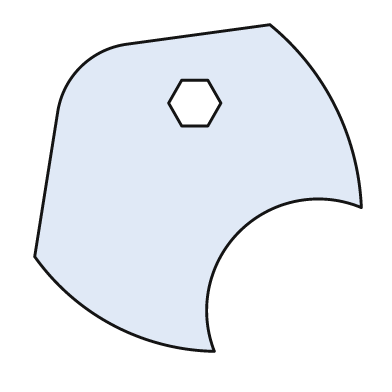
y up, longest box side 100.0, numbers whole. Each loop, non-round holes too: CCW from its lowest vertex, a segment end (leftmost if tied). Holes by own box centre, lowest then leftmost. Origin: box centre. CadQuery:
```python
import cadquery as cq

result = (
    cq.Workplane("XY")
    .moveTo(5.0, -50.0)
    .threePointArc((13.0, -13.0), (50.0, -6.0))
    .threePointArc((42.0, 25.0), (22.0, 50.0))
    .lineTo(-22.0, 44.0)
    .threePointArc((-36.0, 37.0), (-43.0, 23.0))
    .lineTo(-50.0, -21.0)
    .threePointArc((-26.0, -42.0), (5.0, -50.0))
    .close()
    .moveTo(-5.0, 19.0)
    .lineTo(3.0, 19.0)
    .lineTo(7.0, 26.0)
    .lineTo(3.0, 33.0)
    .lineTo(-5.0, 33.0)
    .lineTo(-9.0, 26.0)
    .close()
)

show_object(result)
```